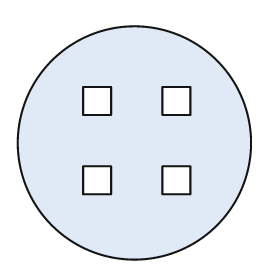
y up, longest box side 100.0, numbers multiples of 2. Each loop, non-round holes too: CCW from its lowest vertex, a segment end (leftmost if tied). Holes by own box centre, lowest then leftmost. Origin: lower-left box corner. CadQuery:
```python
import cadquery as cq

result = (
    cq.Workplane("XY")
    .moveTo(50.0, 50.0)
    .circle(50.0)
    .moveTo(28.0, 28.0)
    .lineTo(40.0, 28.0)
    .lineTo(40.0, 40.0)
    .lineTo(28.0, 40.0)
    .close()
    .moveTo(62.0, 28.0)
    .lineTo(74.0, 28.0)
    .lineTo(74.0, 40.0)
    .lineTo(62.0, 40.0)
    .close()
    .moveTo(28.0, 62.0)
    .lineTo(40.0, 62.0)
    .lineTo(40.0, 74.0)
    .lineTo(28.0, 74.0)
    .close()
    .moveTo(62.0, 62.0)
    .lineTo(74.0, 62.0)
    .lineTo(74.0, 74.0)
    .lineTo(62.0, 74.0)
    .close()
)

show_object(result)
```